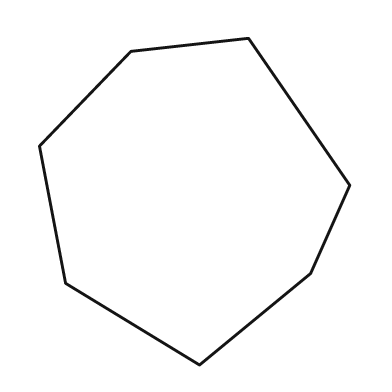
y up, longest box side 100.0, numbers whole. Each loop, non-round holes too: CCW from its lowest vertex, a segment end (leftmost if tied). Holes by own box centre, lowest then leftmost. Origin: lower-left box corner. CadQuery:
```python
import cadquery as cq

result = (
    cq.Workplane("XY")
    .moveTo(49.0, 0.0)
    .lineTo(83.0, 28.0)
    .lineTo(95.0, 55.0)
    .lineTo(64.0, 100.0)
    .lineTo(28.0, 96.0)
    .lineTo(0.0, 67.0)
    .lineTo(8.0, 25.0)
    .close()
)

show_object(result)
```